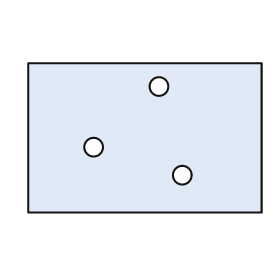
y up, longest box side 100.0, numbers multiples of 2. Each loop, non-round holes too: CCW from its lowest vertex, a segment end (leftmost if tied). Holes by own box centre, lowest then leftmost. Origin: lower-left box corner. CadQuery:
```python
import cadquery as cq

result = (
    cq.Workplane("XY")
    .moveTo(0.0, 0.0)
    .lineTo(100.0, 0.0)
    .lineTo(100.0, 64.0)
    .lineTo(0.0, 64.0)
    .close()
    .moveTo(66.0, 16.0)
    .circle(4.0)
    .moveTo(28.0, 28.0)
    .circle(4.0)
    .moveTo(56.0, 54.0)
    .circle(4.0)
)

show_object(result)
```